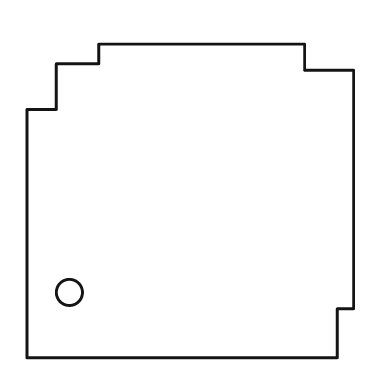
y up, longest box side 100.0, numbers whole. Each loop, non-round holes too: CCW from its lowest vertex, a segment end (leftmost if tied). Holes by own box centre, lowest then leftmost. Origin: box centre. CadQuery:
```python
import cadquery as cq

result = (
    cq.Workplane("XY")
    .moveTo(-50.0, -48.0)
    .lineTo(45.0, -48.0)
    .lineTo(45.0, -33.0)
    .lineTo(50.0, -33.0)
    .lineTo(50.0, 40.0)
    .lineTo(35.0, 40.0)
    .lineTo(35.0, 48.0)
    .lineTo(-28.0, 48.0)
    .lineTo(-28.0, 42.0)
    .lineTo(-41.0, 42.0)
    .lineTo(-41.0, 28.0)
    .lineTo(-50.0, 28.0)
    .close()
    .moveTo(-37.0, -28.0)
    .circle(4.0)
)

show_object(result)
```